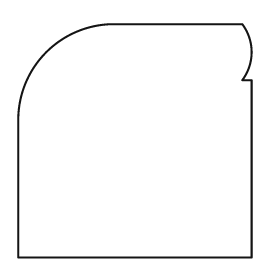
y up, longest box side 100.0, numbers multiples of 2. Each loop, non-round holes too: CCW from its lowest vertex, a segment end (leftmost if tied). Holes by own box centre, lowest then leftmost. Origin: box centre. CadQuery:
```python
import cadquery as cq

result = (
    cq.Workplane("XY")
    .moveTo(-50.0, -50.0)
    .lineTo(50.0, -50.0)
    .lineTo(50.0, 26.0)
    .lineTo(46.0, 26.0)
    .threePointArc((50.0, 38.0), (46.0, 50.0))
    .lineTo(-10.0, 50.0)
    .threePointArc((-38.0, 38.0), (-50.0, 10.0))
    .close()
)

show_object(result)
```